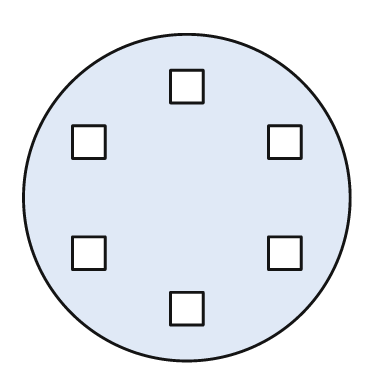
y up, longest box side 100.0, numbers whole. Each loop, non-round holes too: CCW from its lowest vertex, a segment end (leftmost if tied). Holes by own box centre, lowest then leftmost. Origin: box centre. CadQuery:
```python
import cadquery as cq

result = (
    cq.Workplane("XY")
    .moveTo(0.0, 0.0)
    .circle(50.0)
    .moveTo(-5.0, -39.0)
    .lineTo(5.0, -39.0)
    .lineTo(5.0, -29.0)
    .lineTo(-5.0, -29.0)
    .close()
    .moveTo(-35.0, -22.0)
    .lineTo(-25.0, -22.0)
    .lineTo(-25.0, -12.0)
    .lineTo(-35.0, -12.0)
    .close()
    .moveTo(25.0, -22.0)
    .lineTo(35.0, -22.0)
    .lineTo(35.0, -12.0)
    .lineTo(25.0, -12.0)
    .close()
    .moveTo(-35.0, 12.0)
    .lineTo(-25.0, 12.0)
    .lineTo(-25.0, 22.0)
    .lineTo(-35.0, 22.0)
    .close()
    .moveTo(25.0, 12.0)
    .lineTo(35.0, 12.0)
    .lineTo(35.0, 22.0)
    .lineTo(25.0, 22.0)
    .close()
    .moveTo(-5.0, 29.0)
    .lineTo(5.0, 29.0)
    .lineTo(5.0, 39.0)
    .lineTo(-5.0, 39.0)
    .close()
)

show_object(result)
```